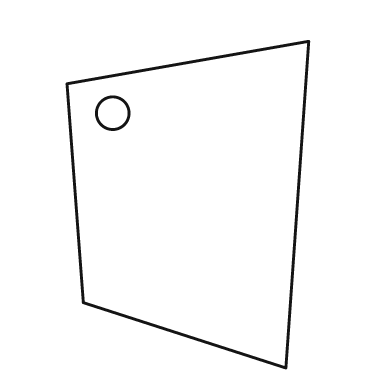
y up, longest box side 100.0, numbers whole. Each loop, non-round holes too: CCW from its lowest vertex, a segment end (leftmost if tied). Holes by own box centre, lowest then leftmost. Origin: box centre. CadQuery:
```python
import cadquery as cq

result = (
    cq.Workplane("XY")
    .moveTo(30.0, -50.0)
    .lineTo(37.0, 50.0)
    .lineTo(-37.0, 37.0)
    .lineTo(-32.0, -30.0)
    .close()
    .moveTo(-23.0, 28.0)
    .circle(5.0)
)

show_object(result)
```